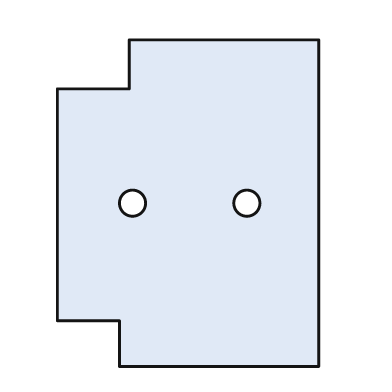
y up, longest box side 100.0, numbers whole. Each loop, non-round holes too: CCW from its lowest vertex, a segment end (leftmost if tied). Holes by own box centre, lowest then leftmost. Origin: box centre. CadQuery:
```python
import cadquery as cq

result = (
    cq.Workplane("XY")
    .moveTo(-21.0, -50.0)
    .lineTo(40.0, -50.0)
    .lineTo(40.0, 50.0)
    .lineTo(-18.0, 50.0)
    .lineTo(-18.0, 35.0)
    .lineTo(-40.0, 35.0)
    .lineTo(-40.0, -36.0)
    .lineTo(-21.0, -36.0)
    .close()
    .moveTo(-17.0, 0.0)
    .circle(4.0)
    .moveTo(18.0, 0.0)
    .circle(4.0)
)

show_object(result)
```